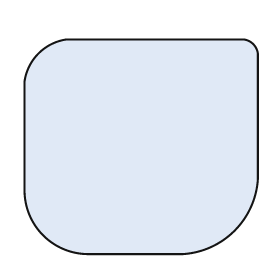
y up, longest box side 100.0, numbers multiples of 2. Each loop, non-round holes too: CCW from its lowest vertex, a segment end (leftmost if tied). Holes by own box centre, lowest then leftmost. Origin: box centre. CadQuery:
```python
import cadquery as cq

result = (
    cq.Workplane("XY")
    .moveTo(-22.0, -46.0)
    .lineTo(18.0, -46.0)
    .threePointArc((40.0, -36.0), (50.0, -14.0))
    .lineTo(50.0, 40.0)
    .threePointArc((48.0, 44.0), (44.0, 46.0))
    .lineTo(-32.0, 46.0)
    .threePointArc((-44.0, 40.0), (-50.0, 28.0))
    .lineTo(-50.0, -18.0)
    .threePointArc((-42.0, -38.0), (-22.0, -46.0))
    .close()
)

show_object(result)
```